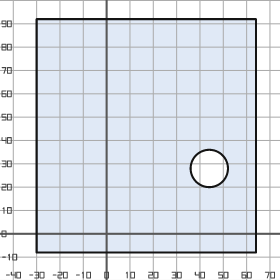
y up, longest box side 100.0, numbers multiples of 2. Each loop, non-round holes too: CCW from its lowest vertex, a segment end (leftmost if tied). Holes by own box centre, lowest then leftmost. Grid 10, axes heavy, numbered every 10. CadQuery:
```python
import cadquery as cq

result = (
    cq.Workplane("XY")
    .moveTo(-30.0, -8.0)
    .lineTo(64.0, -8.0)
    .lineTo(64.0, 92.0)
    .lineTo(-30.0, 92.0)
    .close()
    .moveTo(44.0, 28.0)
    .circle(8.0)
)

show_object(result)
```